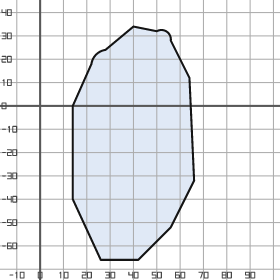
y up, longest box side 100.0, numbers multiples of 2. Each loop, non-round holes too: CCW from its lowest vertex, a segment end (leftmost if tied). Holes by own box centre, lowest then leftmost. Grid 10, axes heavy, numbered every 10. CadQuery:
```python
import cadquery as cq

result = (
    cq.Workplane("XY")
    .moveTo(26.0, -66.0)
    .lineTo(42.0, -66.0)
    .lineTo(56.0, -52.0)
    .lineTo(66.0, -32.0)
    .lineTo(64.0, 12.0)
    .lineTo(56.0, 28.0)
    .threePointArc((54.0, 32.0), (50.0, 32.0))
    .lineTo(40.0, 34.0)
    .lineTo(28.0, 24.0)
    .threePointArc((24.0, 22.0), (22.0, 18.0))
    .lineTo(14.0, 0.0)
    .lineTo(14.0, -40.0)
    .close()
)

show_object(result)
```